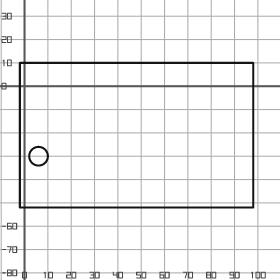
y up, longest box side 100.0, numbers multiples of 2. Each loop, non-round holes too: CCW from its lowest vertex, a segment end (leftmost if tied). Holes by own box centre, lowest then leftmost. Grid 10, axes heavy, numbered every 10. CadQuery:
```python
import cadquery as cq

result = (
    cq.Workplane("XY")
    .moveTo(-2.0, -52.0)
    .lineTo(98.0, -52.0)
    .lineTo(98.0, 10.0)
    .lineTo(-2.0, 10.0)
    .close()
    .moveTo(6.0, -30.0)
    .circle(4.0)
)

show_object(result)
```